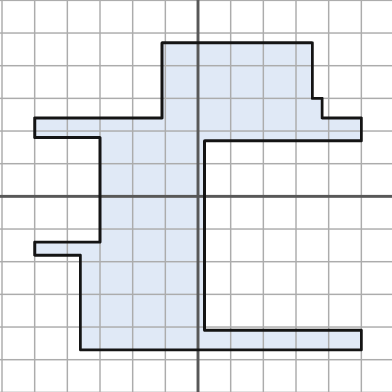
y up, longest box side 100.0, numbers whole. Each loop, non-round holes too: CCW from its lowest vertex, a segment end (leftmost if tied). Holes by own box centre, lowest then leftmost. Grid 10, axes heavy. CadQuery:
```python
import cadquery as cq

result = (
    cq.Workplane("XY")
    .moveTo(-36.0, -47.0)
    .lineTo(50.0, -47.0)
    .lineTo(50.0, -41.0)
    .lineTo(2.0, -41.0)
    .lineTo(2.0, 17.0)
    .lineTo(50.0, 17.0)
    .lineTo(50.0, 24.0)
    .lineTo(38.0, 24.0)
    .lineTo(38.0, 30.0)
    .lineTo(35.0, 30.0)
    .lineTo(35.0, 47.0)
    .lineTo(-11.0, 47.0)
    .lineTo(-11.0, 24.0)
    .lineTo(-50.0, 24.0)
    .lineTo(-50.0, 18.0)
    .lineTo(-30.0, 18.0)
    .lineTo(-30.0, -14.0)
    .lineTo(-50.0, -14.0)
    .lineTo(-50.0, -18.0)
    .lineTo(-36.0, -18.0)
    .close()
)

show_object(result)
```